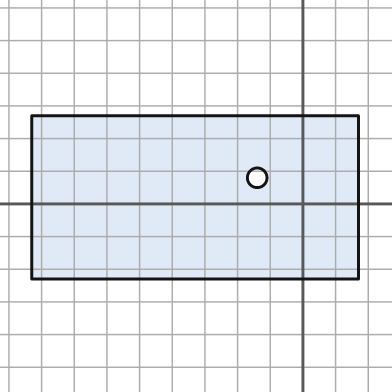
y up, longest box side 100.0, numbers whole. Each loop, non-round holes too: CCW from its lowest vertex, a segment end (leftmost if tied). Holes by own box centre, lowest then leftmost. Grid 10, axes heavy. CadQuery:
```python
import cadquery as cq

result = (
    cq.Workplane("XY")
    .moveTo(-83.0, -23.0)
    .lineTo(17.0, -23.0)
    .lineTo(17.0, 27.0)
    .lineTo(-83.0, 27.0)
    .close()
    .moveTo(-14.0, 8.0)
    .circle(3.0)
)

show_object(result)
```